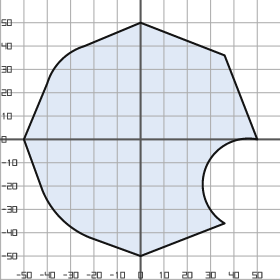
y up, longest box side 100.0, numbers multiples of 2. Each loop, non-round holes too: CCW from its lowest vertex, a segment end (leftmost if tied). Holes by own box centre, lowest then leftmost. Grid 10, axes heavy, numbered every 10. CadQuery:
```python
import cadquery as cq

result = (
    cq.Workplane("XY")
    .moveTo(0.0, -50.0)
    .lineTo(36.0, -36.0)
    .threePointArc((28.0, -12.0), (50.0, 0.0))
    .lineTo(36.0, 36.0)
    .lineTo(0.0, 50.0)
    .lineTo(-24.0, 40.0)
    .threePointArc((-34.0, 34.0), (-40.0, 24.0))
    .lineTo(-50.0, 0.0)
    .lineTo(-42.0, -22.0)
    .threePointArc((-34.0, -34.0), (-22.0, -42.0))
    .close()
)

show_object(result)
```